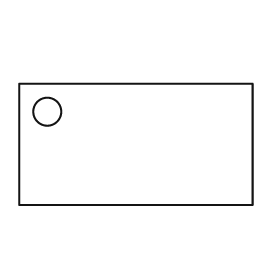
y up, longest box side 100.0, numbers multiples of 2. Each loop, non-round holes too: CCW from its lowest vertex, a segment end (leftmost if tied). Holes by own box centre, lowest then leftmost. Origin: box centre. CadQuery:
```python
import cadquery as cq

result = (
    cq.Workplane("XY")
    .moveTo(-50.0, -26.0)
    .lineTo(50.0, -26.0)
    .lineTo(50.0, 26.0)
    .lineTo(-50.0, 26.0)
    .close()
    .moveTo(-38.0, 14.0)
    .circle(6.0)
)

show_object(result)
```